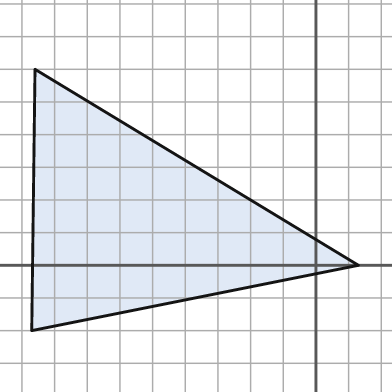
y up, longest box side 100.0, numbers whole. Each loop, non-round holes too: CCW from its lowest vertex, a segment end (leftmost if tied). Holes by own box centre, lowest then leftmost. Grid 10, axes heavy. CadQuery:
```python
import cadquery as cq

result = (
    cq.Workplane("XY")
    .moveTo(-87.0, -20.0)
    .lineTo(13.0, 0.0)
    .lineTo(-86.0, 60.0)
    .close()
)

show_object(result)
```